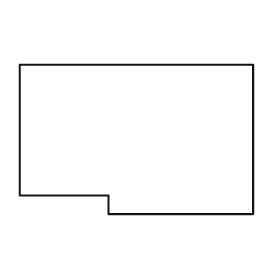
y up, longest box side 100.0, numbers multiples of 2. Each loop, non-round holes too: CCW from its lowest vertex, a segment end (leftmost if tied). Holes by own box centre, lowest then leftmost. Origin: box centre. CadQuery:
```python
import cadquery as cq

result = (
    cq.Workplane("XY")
    .moveTo(-12.0, -32.0)
    .lineTo(50.0, -32.0)
    .lineTo(50.0, 32.0)
    .lineTo(-50.0, 32.0)
    .lineTo(-50.0, -24.0)
    .lineTo(-12.0, -24.0)
    .close()
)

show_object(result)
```